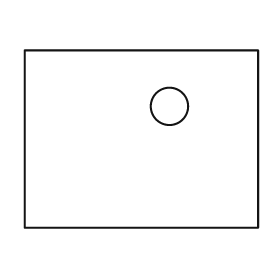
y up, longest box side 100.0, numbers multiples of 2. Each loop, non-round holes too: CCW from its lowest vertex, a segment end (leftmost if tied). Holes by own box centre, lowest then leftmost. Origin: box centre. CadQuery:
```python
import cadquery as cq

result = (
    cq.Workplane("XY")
    .moveTo(-50.0, -38.0)
    .lineTo(50.0, -38.0)
    .lineTo(50.0, 38.0)
    .lineTo(-50.0, 38.0)
    .close()
    .moveTo(12.0, 14.0)
    .circle(8.0)
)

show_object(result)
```